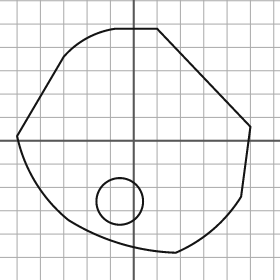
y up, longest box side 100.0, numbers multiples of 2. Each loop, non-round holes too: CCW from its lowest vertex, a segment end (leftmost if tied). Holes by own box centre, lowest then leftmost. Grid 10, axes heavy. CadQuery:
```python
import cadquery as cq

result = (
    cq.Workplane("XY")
    .moveTo(18.0, -48.0)
    .threePointArc((34.0, -38.0), (46.0, -24.0))
    .lineTo(50.0, 6.0)
    .lineTo(10.0, 48.0)
    .lineTo(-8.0, 48.0)
    .threePointArc((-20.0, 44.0), (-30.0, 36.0))
    .lineTo(-50.0, 2.0)
    .threePointArc((-42.0, -18.0), (-28.0, -34.0))
    .threePointArc((-6.0, -44.0), (18.0, -48.0))
    .close()
    .moveTo(-6.0, -26.0)
    .circle(10.0)
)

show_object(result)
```